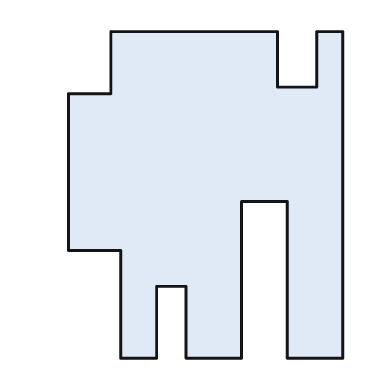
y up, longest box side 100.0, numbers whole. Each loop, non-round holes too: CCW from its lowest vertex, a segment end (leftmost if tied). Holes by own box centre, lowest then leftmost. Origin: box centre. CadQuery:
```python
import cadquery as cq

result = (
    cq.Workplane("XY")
    .moveTo(-26.0, -50.0)
    .lineTo(-15.0, -50.0)
    .lineTo(-15.0, -28.0)
    .lineTo(-6.0, -28.0)
    .lineTo(-6.0, -50.0)
    .lineTo(11.0, -50.0)
    .lineTo(11.0, -2.0)
    .lineTo(25.0, -2.0)
    .lineTo(25.0, -50.0)
    .lineTo(42.0, -50.0)
    .lineTo(42.0, 50.0)
    .lineTo(34.0, 50.0)
    .lineTo(34.0, 33.0)
    .lineTo(22.0, 33.0)
    .lineTo(22.0, 50.0)
    .lineTo(-29.0, 50.0)
    .lineTo(-29.0, 31.0)
    .lineTo(-42.0, 31.0)
    .lineTo(-42.0, -17.0)
    .lineTo(-26.0, -17.0)
    .close()
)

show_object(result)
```